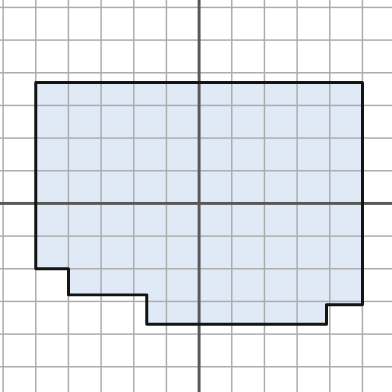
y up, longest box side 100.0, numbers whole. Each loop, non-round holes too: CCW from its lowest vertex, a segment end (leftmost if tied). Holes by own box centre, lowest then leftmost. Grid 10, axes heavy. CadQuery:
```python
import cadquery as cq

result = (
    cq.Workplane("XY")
    .moveTo(-16.0, -37.0)
    .lineTo(39.0, -37.0)
    .lineTo(39.0, -31.0)
    .lineTo(50.0, -31.0)
    .lineTo(50.0, 37.0)
    .lineTo(-50.0, 37.0)
    .lineTo(-50.0, -20.0)
    .lineTo(-40.0, -20.0)
    .lineTo(-40.0, -28.0)
    .lineTo(-16.0, -28.0)
    .close()
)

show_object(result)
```